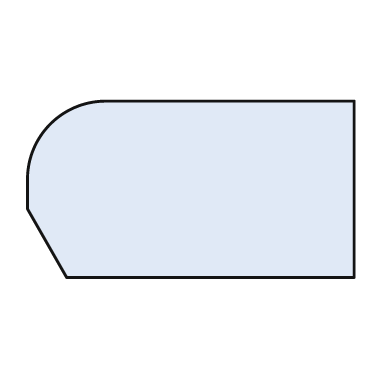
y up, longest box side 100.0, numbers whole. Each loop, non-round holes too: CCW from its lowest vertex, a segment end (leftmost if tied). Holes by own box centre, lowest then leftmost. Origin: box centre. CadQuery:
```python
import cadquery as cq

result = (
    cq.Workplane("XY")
    .moveTo(-38.0, -27.0)
    .lineTo(50.0, -27.0)
    .lineTo(50.0, 27.0)
    .lineTo(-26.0, 27.0)
    .threePointArc((-43.0, 20.0), (-50.0, 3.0))
    .lineTo(-50.0, -6.0)
    .close()
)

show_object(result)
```